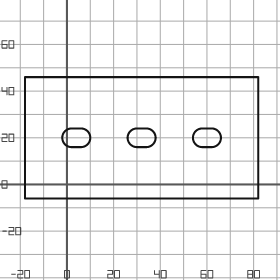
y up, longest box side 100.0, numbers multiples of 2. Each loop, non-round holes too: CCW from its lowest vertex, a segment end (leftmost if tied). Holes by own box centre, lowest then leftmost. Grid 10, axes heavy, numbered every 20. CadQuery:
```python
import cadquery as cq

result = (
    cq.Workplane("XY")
    .moveTo(-18.0, -6.0)
    .lineTo(82.0, -6.0)
    .lineTo(82.0, 46.0)
    .lineTo(-18.0, 46.0)
    .close()
    .moveTo(2.0, 16.0)
    .lineTo(6.0, 16.0)
    .threePointArc((10.0, 20.0), (6.0, 24.0))
    .lineTo(2.0, 24.0)
    .threePointArc((-2.0, 20.0), (2.0, 16.0))
    .close()
    .moveTo(30.0, 16.0)
    .lineTo(34.0, 16.0)
    .threePointArc((38.0, 20.0), (34.0, 24.0))
    .lineTo(30.0, 24.0)
    .threePointArc((26.0, 20.0), (30.0, 16.0))
    .close()
    .moveTo(58.0, 16.0)
    .lineTo(62.0, 16.0)
    .threePointArc((66.0, 20.0), (62.0, 24.0))
    .lineTo(58.0, 24.0)
    .threePointArc((54.0, 20.0), (58.0, 16.0))
    .close()
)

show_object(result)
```